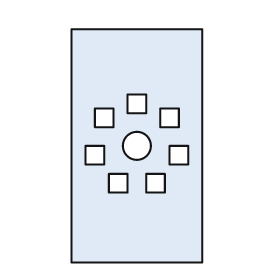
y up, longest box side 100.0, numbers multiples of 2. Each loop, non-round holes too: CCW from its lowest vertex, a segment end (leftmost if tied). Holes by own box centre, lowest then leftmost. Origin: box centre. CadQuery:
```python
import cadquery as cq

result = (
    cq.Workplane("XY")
    .moveTo(-28.0, -50.0)
    .lineTo(28.0, -50.0)
    .lineTo(28.0, 50.0)
    .lineTo(-28.0, 50.0)
    .close()
    .moveTo(-12.0, -20.0)
    .lineTo(-4.0, -20.0)
    .lineTo(-4.0, -12.0)
    .lineTo(-12.0, -12.0)
    .close()
    .moveTo(4.0, -20.0)
    .lineTo(12.0, -20.0)
    .lineTo(12.0, -12.0)
    .lineTo(4.0, -12.0)
    .close()
    .moveTo(-22.0, -8.0)
    .lineTo(-14.0, -8.0)
    .lineTo(-14.0, 0.0)
    .lineTo(-22.0, 0.0)
    .close()
    .moveTo(14.0, -8.0)
    .lineTo(22.0, -8.0)
    .lineTo(22.0, 0.0)
    .lineTo(14.0, 0.0)
    .close()
    .moveTo(0.0, 0.0)
    .circle(6.0)
    .moveTo(-18.0, 8.0)
    .lineTo(-10.0, 8.0)
    .lineTo(-10.0, 16.0)
    .lineTo(-18.0, 16.0)
    .close()
    .moveTo(10.0, 8.0)
    .lineTo(18.0, 8.0)
    .lineTo(18.0, 16.0)
    .lineTo(10.0, 16.0)
    .close()
    .moveTo(-4.0, 14.0)
    .lineTo(4.0, 14.0)
    .lineTo(4.0, 22.0)
    .lineTo(-4.0, 22.0)
    .close()
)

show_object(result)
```